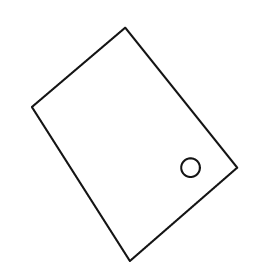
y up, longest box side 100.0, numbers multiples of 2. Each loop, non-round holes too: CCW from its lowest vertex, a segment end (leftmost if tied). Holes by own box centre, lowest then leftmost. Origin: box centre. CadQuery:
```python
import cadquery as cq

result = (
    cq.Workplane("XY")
    .moveTo(-2.0, -50.0)
    .lineTo(44.0, -10.0)
    .lineTo(-4.0, 50.0)
    .lineTo(-44.0, 16.0)
    .close()
    .moveTo(24.0, -10.0)
    .circle(4.0)
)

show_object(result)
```